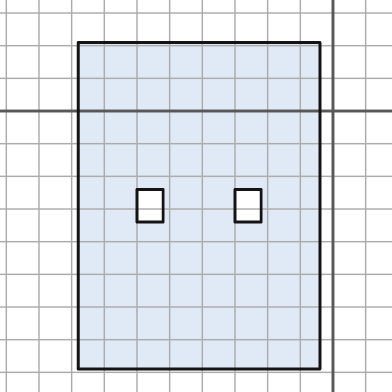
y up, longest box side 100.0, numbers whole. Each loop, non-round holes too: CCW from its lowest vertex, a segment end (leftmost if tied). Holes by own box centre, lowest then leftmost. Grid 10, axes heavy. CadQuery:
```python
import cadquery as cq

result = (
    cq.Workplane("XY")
    .moveTo(-78.0, -79.0)
    .lineTo(-4.0, -79.0)
    .lineTo(-4.0, 21.0)
    .lineTo(-78.0, 21.0)
    .close()
    .moveTo(-60.0, -34.0)
    .lineTo(-52.0, -34.0)
    .lineTo(-52.0, -24.0)
    .lineTo(-60.0, -24.0)
    .close()
    .moveTo(-30.0, -34.0)
    .lineTo(-22.0, -34.0)
    .lineTo(-22.0, -24.0)
    .lineTo(-30.0, -24.0)
    .close()
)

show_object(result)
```